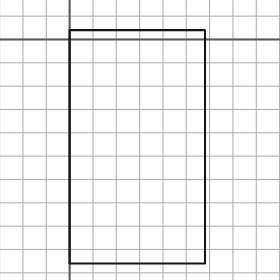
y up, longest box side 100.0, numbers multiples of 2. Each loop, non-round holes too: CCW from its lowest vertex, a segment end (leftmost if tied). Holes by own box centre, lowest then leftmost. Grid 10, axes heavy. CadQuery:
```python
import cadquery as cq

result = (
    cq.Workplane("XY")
    .moveTo(0.0, -96.0)
    .lineTo(58.0, -96.0)
    .lineTo(58.0, 4.0)
    .lineTo(0.0, 4.0)
    .close()
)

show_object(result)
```